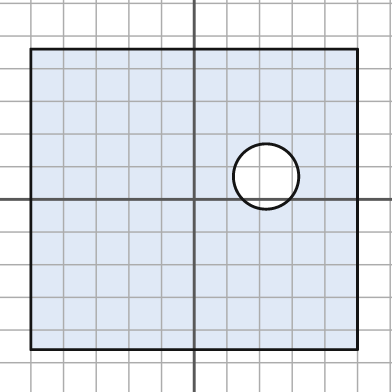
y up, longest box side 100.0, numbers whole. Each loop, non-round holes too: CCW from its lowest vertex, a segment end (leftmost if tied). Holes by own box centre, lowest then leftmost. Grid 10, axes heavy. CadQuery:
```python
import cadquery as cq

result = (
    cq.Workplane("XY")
    .moveTo(-50.0, -46.0)
    .lineTo(50.0, -46.0)
    .lineTo(50.0, 46.0)
    .lineTo(-50.0, 46.0)
    .close()
    .moveTo(22.0, 7.0)
    .circle(10.0)
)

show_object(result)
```